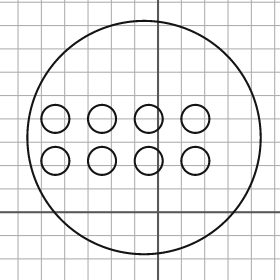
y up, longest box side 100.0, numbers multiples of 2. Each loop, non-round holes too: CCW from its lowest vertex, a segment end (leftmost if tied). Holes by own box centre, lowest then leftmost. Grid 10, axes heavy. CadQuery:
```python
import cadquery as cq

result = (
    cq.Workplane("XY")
    .moveTo(-6.0, 32.0)
    .circle(50.0)
    .moveTo(-44.0, 22.0)
    .circle(6.0)
    .moveTo(-24.0, 22.0)
    .circle(6.0)
    .moveTo(-4.0, 22.0)
    .circle(6.0)
    .moveTo(16.0, 22.0)
    .circle(6.0)
    .moveTo(-44.0, 40.0)
    .circle(6.0)
    .moveTo(-24.0, 40.0)
    .circle(6.0)
    .moveTo(-4.0, 40.0)
    .circle(6.0)
    .moveTo(16.0, 40.0)
    .circle(6.0)
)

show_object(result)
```